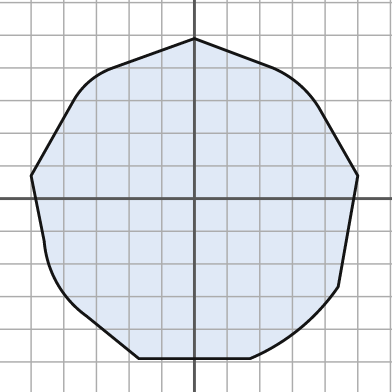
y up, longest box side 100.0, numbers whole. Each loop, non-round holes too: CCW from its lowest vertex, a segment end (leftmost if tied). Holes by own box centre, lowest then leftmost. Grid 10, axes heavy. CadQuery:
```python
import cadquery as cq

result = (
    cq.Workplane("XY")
    .moveTo(-17.0, -49.0)
    .lineTo(17.0, -49.0)
    .threePointArc((32.0, -40.0), (44.0, -27.0))
    .lineTo(50.0, 7.0)
    .lineTo(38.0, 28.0)
    .threePointArc((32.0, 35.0), (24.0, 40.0))
    .lineTo(0.0, 49.0)
    .lineTo(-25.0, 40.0)
    .threePointArc((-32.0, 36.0), (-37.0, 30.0))
    .lineTo(-50.0, 7.0)
    .lineTo(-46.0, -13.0)
    .threePointArc((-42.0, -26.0), (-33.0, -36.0))
    .close()
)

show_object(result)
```